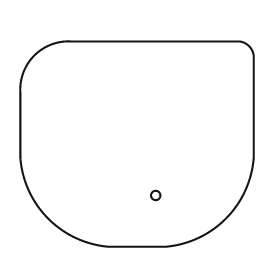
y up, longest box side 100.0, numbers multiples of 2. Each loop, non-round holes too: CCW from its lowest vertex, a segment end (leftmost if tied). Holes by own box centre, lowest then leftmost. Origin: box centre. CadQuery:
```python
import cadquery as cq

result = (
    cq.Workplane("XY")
    .moveTo(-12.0, -44.0)
    .lineTo(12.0, -44.0)
    .threePointArc((38.0, -32.0), (50.0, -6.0))
    .lineTo(50.0, 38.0)
    .threePointArc((48.0, 42.0), (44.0, 44.0))
    .lineTo(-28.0, 44.0)
    .threePointArc((-44.0, 38.0), (-50.0, 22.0))
    .lineTo(-50.0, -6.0)
    .threePointArc((-38.0, -32.0), (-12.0, -44.0))
    .close()
    .moveTo(8.0, -22.0)
    .circle(2.0)
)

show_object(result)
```